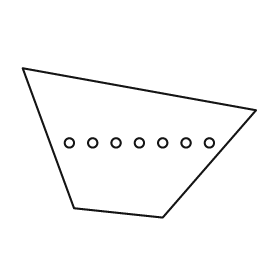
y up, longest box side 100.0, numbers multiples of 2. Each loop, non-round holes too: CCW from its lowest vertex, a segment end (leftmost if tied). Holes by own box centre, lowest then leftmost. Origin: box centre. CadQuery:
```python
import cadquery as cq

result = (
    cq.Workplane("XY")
    .moveTo(10.0, -32.0)
    .lineTo(50.0, 14.0)
    .lineTo(-50.0, 32.0)
    .lineTo(-28.0, -28.0)
    .close()
    .moveTo(-30.0, 0.0)
    .circle(2.0)
    .moveTo(-20.0, 0.0)
    .circle(2.0)
    .moveTo(-10.0, 0.0)
    .circle(2.0)
    .moveTo(0.0, 0.0)
    .circle(2.0)
    .moveTo(10.0, 0.0)
    .circle(2.0)
    .moveTo(20.0, 0.0)
    .circle(2.0)
    .moveTo(30.0, 0.0)
    .circle(2.0)
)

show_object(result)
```